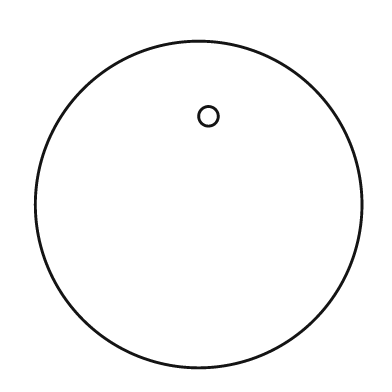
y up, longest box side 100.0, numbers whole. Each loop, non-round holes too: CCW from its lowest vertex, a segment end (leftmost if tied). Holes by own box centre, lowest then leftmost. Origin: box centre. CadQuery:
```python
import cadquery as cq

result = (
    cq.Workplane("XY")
    .moveTo(0.0, 0.0)
    .circle(50.0)
    .moveTo(3.0, 27.0)
    .circle(3.0)
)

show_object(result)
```